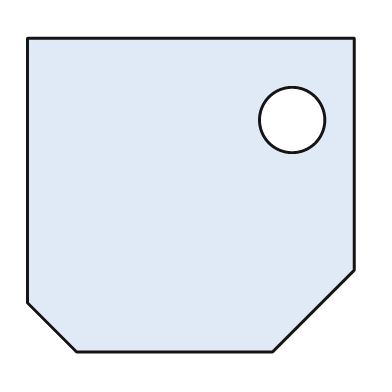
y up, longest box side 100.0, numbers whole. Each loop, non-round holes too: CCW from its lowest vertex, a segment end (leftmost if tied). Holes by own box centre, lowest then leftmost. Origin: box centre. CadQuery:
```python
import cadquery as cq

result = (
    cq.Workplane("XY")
    .moveTo(-35.0, -48.0)
    .lineTo(25.0, -48.0)
    .lineTo(50.0, -23.0)
    .lineTo(50.0, 48.0)
    .lineTo(-50.0, 48.0)
    .lineTo(-50.0, -33.0)
    .close()
    .moveTo(31.0, 23.0)
    .circle(10.0)
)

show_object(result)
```